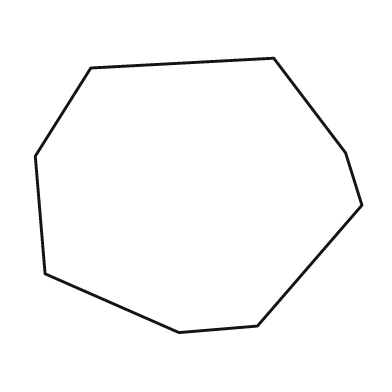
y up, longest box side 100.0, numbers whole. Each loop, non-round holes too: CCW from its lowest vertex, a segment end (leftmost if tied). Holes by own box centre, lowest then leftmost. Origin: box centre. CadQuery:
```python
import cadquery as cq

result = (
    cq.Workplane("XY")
    .moveTo(-6.0, -42.0)
    .lineTo(18.0, -40.0)
    .lineTo(50.0, -3.0)
    .lineTo(45.0, 13.0)
    .lineTo(23.0, 42.0)
    .lineTo(-33.0, 39.0)
    .lineTo(-50.0, 12.0)
    .lineTo(-47.0, -24.0)
    .close()
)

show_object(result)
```